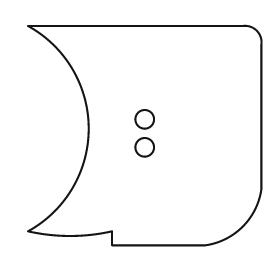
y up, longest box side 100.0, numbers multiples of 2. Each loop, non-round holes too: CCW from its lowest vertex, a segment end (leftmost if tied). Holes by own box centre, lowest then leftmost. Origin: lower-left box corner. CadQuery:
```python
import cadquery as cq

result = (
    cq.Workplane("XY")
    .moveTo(36.0, 0.0)
    .lineTo(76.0, 0.0)
    .threePointArc((92.0, 8.0), (100.0, 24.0))
    .lineTo(100.0, 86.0)
    .threePointArc((98.0, 92.0), (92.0, 94.0))
    .lineTo(0.0, 94.0)
    .threePointArc((26.0, 50.0), (0.0, 6.0))
    .threePointArc((18.0, 4.0), (36.0, 6.0))
    .close()
    .moveTo(50.0, 42.0)
    .circle(4.0)
    .moveTo(50.0, 54.0)
    .circle(4.0)
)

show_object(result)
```